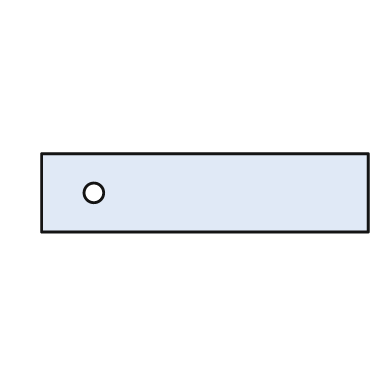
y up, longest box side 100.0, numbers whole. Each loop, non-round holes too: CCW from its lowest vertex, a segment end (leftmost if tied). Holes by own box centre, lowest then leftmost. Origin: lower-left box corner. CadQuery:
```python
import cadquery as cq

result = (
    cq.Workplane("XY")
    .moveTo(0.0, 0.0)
    .lineTo(100.0, 0.0)
    .lineTo(100.0, 24.0)
    .lineTo(0.0, 24.0)
    .close()
    .moveTo(16.0, 12.0)
    .circle(3.0)
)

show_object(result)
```